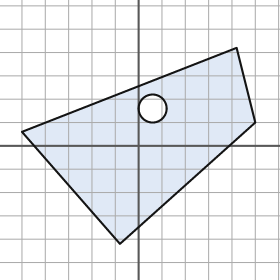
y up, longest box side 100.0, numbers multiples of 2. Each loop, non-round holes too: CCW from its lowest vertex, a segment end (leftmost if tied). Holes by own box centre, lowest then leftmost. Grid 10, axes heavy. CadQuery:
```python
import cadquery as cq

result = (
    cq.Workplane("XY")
    .moveTo(-8.0, -42.0)
    .lineTo(50.0, 10.0)
    .lineTo(42.0, 42.0)
    .lineTo(-50.0, 6.0)
    .close()
    .moveTo(6.0, 16.0)
    .circle(6.0)
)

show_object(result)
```